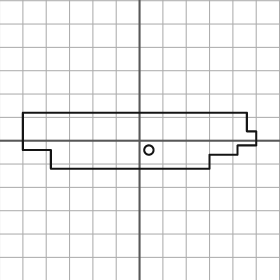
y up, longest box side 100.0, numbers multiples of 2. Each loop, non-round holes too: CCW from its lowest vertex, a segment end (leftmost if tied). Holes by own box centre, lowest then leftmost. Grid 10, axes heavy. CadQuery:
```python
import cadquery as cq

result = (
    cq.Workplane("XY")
    .moveTo(-38.0, -12.0)
    .lineTo(30.0, -12.0)
    .lineTo(30.0, -6.0)
    .lineTo(42.0, -6.0)
    .lineTo(42.0, -2.0)
    .lineTo(50.0, -2.0)
    .lineTo(50.0, 4.0)
    .lineTo(46.0, 4.0)
    .lineTo(46.0, 12.0)
    .lineTo(-50.0, 12.0)
    .lineTo(-50.0, -4.0)
    .lineTo(-38.0, -4.0)
    .close()
    .moveTo(4.0, -4.0)
    .circle(2.0)
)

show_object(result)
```